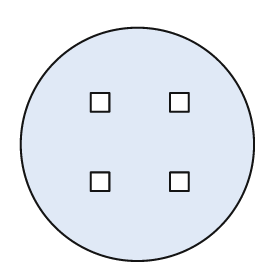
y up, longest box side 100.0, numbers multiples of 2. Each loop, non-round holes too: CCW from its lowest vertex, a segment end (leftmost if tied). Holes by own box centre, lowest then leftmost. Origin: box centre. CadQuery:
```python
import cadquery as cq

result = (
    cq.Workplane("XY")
    .moveTo(0.0, 0.0)
    .circle(50.0)
    .moveTo(-20.0, -20.0)
    .lineTo(-12.0, -20.0)
    .lineTo(-12.0, -12.0)
    .lineTo(-20.0, -12.0)
    .close()
    .moveTo(14.0, -20.0)
    .lineTo(22.0, -20.0)
    .lineTo(22.0, -12.0)
    .lineTo(14.0, -12.0)
    .close()
    .moveTo(-20.0, 14.0)
    .lineTo(-12.0, 14.0)
    .lineTo(-12.0, 22.0)
    .lineTo(-20.0, 22.0)
    .close()
    .moveTo(14.0, 14.0)
    .lineTo(22.0, 14.0)
    .lineTo(22.0, 22.0)
    .lineTo(14.0, 22.0)
    .close()
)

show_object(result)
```